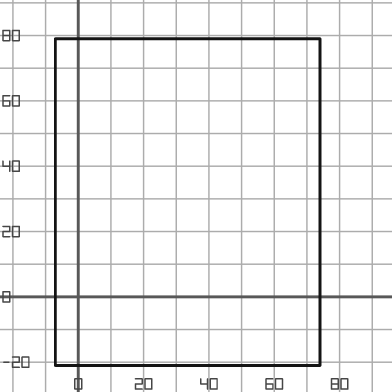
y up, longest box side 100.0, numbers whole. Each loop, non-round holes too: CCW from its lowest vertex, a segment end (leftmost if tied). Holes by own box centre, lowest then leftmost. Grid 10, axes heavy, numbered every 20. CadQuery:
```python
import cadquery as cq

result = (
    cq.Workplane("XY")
    .moveTo(-7.0, -21.0)
    .lineTo(74.0, -21.0)
    .lineTo(74.0, 79.0)
    .lineTo(-7.0, 79.0)
    .close()
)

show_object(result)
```